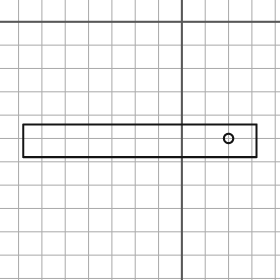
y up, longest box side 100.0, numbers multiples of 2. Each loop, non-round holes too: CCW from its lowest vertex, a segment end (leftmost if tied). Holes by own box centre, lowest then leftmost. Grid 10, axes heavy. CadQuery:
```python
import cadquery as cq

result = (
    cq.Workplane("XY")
    .moveTo(-68.0, -58.0)
    .lineTo(32.0, -58.0)
    .lineTo(32.0, -44.0)
    .lineTo(-68.0, -44.0)
    .close()
    .moveTo(20.0, -50.0)
    .circle(2.0)
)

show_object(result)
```